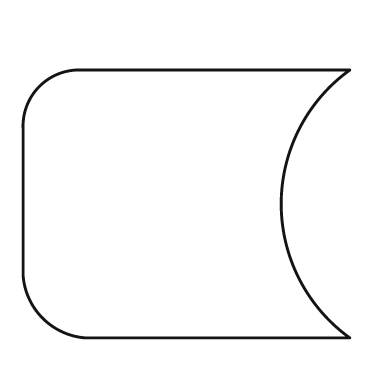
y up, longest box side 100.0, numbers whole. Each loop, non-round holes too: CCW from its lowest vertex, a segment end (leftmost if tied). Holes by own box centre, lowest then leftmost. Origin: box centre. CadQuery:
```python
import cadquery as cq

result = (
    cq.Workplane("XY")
    .moveTo(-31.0, -41.0)
    .lineTo(50.0, -41.0)
    .threePointArc((29.0, 0.0), (50.0, 41.0))
    .lineTo(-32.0, 41.0)
    .threePointArc((-45.0, 36.0), (-50.0, 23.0))
    .lineTo(-50.0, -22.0)
    .threePointArc((-44.0, -35.0), (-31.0, -41.0))
    .close()
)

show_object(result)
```